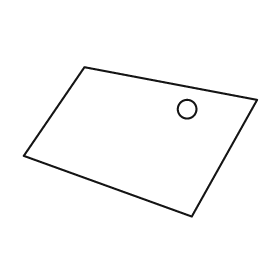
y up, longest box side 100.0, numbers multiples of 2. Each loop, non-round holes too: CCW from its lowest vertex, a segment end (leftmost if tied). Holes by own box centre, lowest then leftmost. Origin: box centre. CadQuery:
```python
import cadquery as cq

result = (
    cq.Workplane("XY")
    .moveTo(22.0, -32.0)
    .lineTo(50.0, 18.0)
    .lineTo(-24.0, 32.0)
    .lineTo(-50.0, -6.0)
    .close()
    .moveTo(20.0, 14.0)
    .circle(4.0)
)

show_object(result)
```